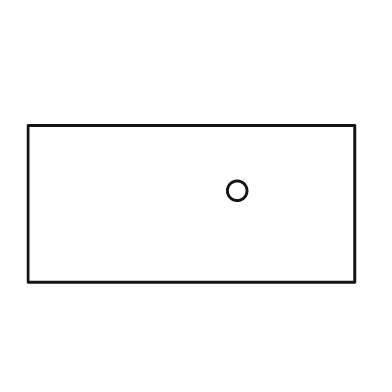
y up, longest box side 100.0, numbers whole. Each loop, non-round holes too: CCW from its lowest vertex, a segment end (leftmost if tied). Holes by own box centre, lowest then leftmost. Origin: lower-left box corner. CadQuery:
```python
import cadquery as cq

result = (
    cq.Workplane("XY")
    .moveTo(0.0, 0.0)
    .lineTo(100.0, 0.0)
    .lineTo(100.0, 48.0)
    .lineTo(0.0, 48.0)
    .close()
    .moveTo(64.0, 28.0)
    .circle(3.0)
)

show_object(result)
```